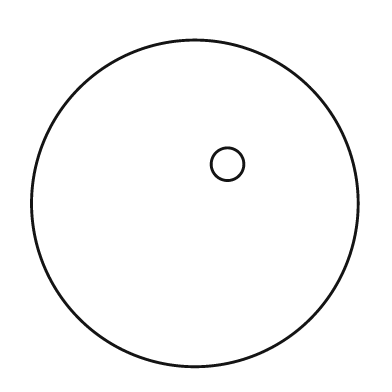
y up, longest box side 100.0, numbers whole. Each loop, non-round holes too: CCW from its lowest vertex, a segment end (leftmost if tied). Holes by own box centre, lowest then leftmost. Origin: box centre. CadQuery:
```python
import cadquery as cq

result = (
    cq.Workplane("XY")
    .moveTo(0.0, 0.0)
    .circle(50.0)
    .moveTo(10.0, 12.0)
    .circle(5.0)
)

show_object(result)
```